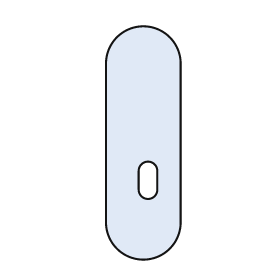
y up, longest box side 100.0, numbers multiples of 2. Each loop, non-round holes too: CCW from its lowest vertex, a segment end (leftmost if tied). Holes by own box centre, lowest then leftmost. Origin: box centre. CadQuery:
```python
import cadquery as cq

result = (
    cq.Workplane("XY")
    .moveTo(-16.0, -34.0)
    .threePointArc((0.0, -50.0), (16.0, -34.0))
    .lineTo(16.0, 34.0)
    .threePointArc((0.0, 50.0), (-16.0, 34.0))
    .close()
    .moveTo(-2.0, -20.0)
    .threePointArc((2.0, -24.0), (6.0, -20.0))
    .lineTo(6.0, -12.0)
    .threePointArc((2.0, -8.0), (-2.0, -12.0))
    .close()
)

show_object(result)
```